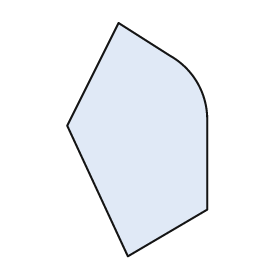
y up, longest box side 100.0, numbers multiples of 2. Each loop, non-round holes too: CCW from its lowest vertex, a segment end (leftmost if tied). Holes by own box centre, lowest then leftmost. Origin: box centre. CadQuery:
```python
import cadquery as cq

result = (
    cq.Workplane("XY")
    .moveTo(-4.0, -50.0)
    .lineTo(30.0, -30.0)
    .lineTo(30.0, 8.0)
    .threePointArc((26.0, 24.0), (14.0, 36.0))
    .lineTo(-8.0, 50.0)
    .lineTo(-30.0, 6.0)
    .close()
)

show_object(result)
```